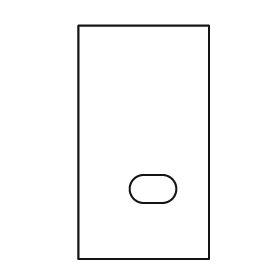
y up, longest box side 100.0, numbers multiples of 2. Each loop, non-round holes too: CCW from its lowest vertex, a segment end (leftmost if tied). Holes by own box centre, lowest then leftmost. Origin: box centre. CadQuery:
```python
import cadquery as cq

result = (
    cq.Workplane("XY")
    .moveTo(-28.0, -50.0)
    .lineTo(28.0, -50.0)
    .lineTo(28.0, 50.0)
    .lineTo(-28.0, 50.0)
    .close()
    .moveTo(0.0, -26.0)
    .lineTo(8.0, -26.0)
    .threePointArc((14.0, -20.0), (8.0, -14.0))
    .lineTo(0.0, -14.0)
    .threePointArc((-6.0, -20.0), (0.0, -26.0))
    .close()
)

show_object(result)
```